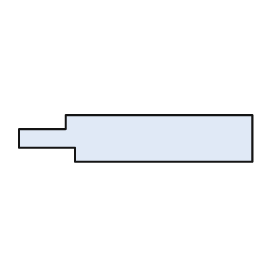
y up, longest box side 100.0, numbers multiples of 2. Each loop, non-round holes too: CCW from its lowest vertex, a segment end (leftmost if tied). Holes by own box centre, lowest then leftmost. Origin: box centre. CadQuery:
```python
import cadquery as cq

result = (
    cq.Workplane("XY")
    .moveTo(-26.0, -10.0)
    .lineTo(50.0, -10.0)
    .lineTo(50.0, 10.0)
    .lineTo(-30.0, 10.0)
    .lineTo(-30.0, 4.0)
    .lineTo(-50.0, 4.0)
    .lineTo(-50.0, -4.0)
    .lineTo(-26.0, -4.0)
    .close()
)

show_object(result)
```